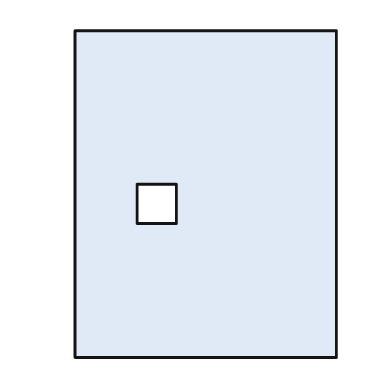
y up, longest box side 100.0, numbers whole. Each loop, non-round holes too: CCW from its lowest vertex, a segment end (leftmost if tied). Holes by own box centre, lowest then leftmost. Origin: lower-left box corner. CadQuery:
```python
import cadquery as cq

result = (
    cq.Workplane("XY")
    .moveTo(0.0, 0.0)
    .lineTo(80.0, 0.0)
    .lineTo(80.0, 100.0)
    .lineTo(0.0, 100.0)
    .close()
    .moveTo(19.0, 41.0)
    .lineTo(31.0, 41.0)
    .lineTo(31.0, 53.0)
    .lineTo(19.0, 53.0)
    .close()
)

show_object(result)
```